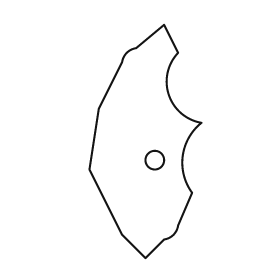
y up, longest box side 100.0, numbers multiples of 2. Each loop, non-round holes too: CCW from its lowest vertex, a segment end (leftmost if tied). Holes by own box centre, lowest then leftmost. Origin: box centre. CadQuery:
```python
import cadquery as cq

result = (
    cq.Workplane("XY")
    .moveTo(0.0, -50.0)
    .lineTo(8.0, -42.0)
    .threePointArc((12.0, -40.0), (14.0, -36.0))
    .lineTo(20.0, -22.0)
    .threePointArc((16.0, -6.0), (24.0, 8.0))
    .threePointArc((10.0, 20.0), (14.0, 38.0))
    .lineTo(8.0, 50.0)
    .lineTo(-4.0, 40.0)
    .threePointArc((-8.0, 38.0), (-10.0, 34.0))
    .lineTo(-20.0, 14.0)
    .lineTo(-24.0, -12.0)
    .lineTo(-10.0, -40.0)
    .close()
    .moveTo(4.0, -8.0)
    .circle(4.0)
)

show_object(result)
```